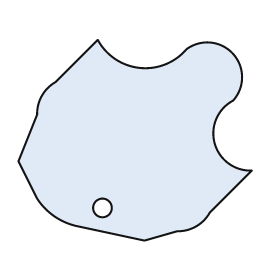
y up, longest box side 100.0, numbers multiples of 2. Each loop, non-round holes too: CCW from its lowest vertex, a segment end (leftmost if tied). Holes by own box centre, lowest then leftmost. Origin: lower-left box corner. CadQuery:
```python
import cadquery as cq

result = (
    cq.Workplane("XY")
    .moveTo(54.0, 0.0)
    .lineTo(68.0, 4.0)
    .threePointArc((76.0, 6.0), (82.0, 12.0))
    .lineTo(100.0, 30.0)
    .threePointArc((84.0, 42.0), (92.0, 60.0))
    .threePointArc((92.0, 80.0), (72.0, 82.0))
    .threePointArc((52.0, 74.0), (34.0, 86.0))
    .lineTo(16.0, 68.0)
    .threePointArc((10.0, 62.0), (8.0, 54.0))
    .lineTo(0.0, 34.0)
    .lineTo(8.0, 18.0)
    .threePointArc((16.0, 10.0), (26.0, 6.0))
    .close()
    .moveTo(36.0, 14.0)
    .circle(4.0)
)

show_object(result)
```